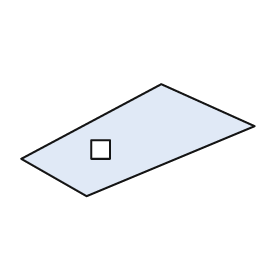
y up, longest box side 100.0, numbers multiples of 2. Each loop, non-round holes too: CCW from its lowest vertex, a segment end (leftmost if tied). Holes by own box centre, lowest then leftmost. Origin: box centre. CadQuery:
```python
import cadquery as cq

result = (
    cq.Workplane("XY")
    .moveTo(-22.0, -24.0)
    .lineTo(50.0, 6.0)
    .lineTo(10.0, 24.0)
    .lineTo(-50.0, -8.0)
    .close()
    .moveTo(-20.0, -8.0)
    .lineTo(-12.0, -8.0)
    .lineTo(-12.0, 0.0)
    .lineTo(-20.0, 0.0)
    .close()
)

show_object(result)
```